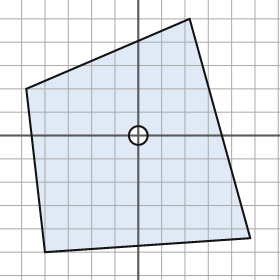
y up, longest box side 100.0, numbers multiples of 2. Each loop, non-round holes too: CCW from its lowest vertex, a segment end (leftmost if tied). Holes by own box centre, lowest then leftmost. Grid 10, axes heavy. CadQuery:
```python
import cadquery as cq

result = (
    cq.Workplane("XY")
    .moveTo(-40.0, -50.0)
    .lineTo(48.0, -44.0)
    .lineTo(22.0, 50.0)
    .lineTo(-48.0, 20.0)
    .close()
    .moveTo(0.0, 0.0)
    .circle(4.0)
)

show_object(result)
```